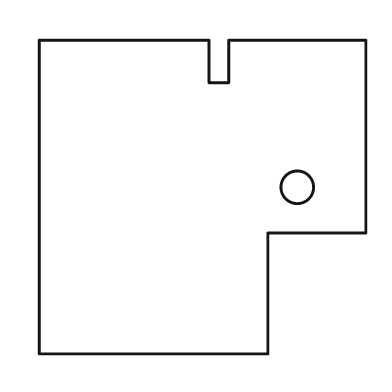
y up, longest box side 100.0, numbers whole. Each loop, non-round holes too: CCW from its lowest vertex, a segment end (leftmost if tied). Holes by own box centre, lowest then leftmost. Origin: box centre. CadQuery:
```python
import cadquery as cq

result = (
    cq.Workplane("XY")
    .moveTo(-50.0, -48.0)
    .lineTo(20.0, -48.0)
    .lineTo(20.0, -11.0)
    .lineTo(50.0, -11.0)
    .lineTo(50.0, 48.0)
    .lineTo(8.0, 48.0)
    .lineTo(8.0, 35.0)
    .lineTo(2.0, 35.0)
    .lineTo(2.0, 48.0)
    .lineTo(-50.0, 48.0)
    .close()
    .moveTo(29.0, 3.0)
    .circle(5.0)
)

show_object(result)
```